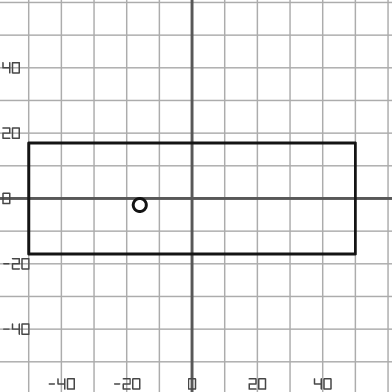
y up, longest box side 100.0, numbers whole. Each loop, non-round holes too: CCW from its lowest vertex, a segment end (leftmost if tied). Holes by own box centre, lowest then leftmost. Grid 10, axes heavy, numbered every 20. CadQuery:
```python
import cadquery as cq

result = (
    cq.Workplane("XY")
    .moveTo(-50.0, -17.0)
    .lineTo(50.0, -17.0)
    .lineTo(50.0, 17.0)
    .lineTo(-50.0, 17.0)
    .close()
    .moveTo(-16.0, -2.0)
    .circle(2.0)
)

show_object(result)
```